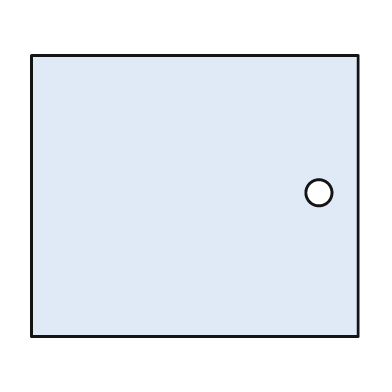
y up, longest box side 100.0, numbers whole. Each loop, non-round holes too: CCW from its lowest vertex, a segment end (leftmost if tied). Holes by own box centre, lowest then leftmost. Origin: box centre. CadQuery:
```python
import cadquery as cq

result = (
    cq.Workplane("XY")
    .moveTo(-50.0, -43.0)
    .lineTo(50.0, -43.0)
    .lineTo(50.0, 43.0)
    .lineTo(-50.0, 43.0)
    .close()
    .moveTo(38.0, 1.0)
    .circle(4.0)
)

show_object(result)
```